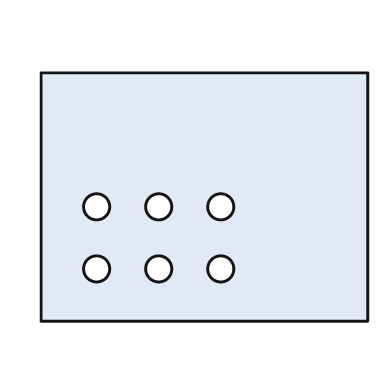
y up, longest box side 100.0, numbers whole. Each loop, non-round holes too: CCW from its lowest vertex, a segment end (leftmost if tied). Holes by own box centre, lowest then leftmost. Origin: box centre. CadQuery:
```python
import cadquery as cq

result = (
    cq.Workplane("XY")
    .moveTo(-50.0, -38.0)
    .lineTo(50.0, -38.0)
    .lineTo(50.0, 38.0)
    .lineTo(-50.0, 38.0)
    .close()
    .moveTo(-33.0, -22.0)
    .circle(4.0)
    .moveTo(-14.0, -22.0)
    .circle(4.0)
    .moveTo(5.0, -22.0)
    .circle(4.0)
    .moveTo(-33.0, -3.0)
    .circle(4.0)
    .moveTo(-14.0, -3.0)
    .circle(4.0)
    .moveTo(5.0, -3.0)
    .circle(4.0)
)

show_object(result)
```